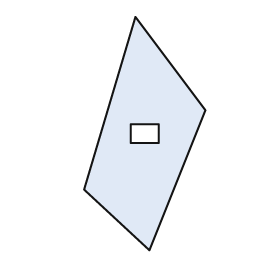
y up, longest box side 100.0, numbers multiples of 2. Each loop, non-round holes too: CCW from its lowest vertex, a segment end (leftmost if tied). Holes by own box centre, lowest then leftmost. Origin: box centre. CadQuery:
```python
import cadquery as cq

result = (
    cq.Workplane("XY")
    .moveTo(2.0, -50.0)
    .lineTo(26.0, 10.0)
    .lineTo(-4.0, 50.0)
    .lineTo(-26.0, -24.0)
    .close()
    .moveTo(-6.0, -4.0)
    .lineTo(6.0, -4.0)
    .lineTo(6.0, 4.0)
    .lineTo(-6.0, 4.0)
    .close()
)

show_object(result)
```